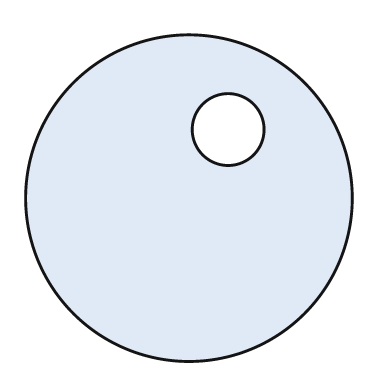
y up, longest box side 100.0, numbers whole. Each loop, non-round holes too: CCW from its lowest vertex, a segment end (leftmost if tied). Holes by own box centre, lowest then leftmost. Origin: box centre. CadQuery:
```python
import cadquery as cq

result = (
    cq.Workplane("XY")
    .moveTo(0.0, 0.0)
    .circle(50.0)
    .moveTo(12.0, 21.0)
    .circle(11.0)
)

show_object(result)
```